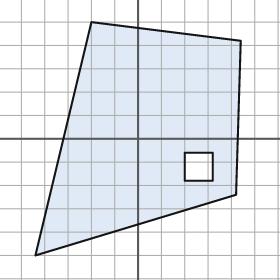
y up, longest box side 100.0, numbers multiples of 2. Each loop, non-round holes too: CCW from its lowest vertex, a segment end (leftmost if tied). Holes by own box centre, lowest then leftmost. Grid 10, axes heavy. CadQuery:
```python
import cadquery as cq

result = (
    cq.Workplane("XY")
    .moveTo(-44.0, -50.0)
    .lineTo(42.0, -24.0)
    .lineTo(44.0, 42.0)
    .lineTo(-20.0, 50.0)
    .close()
    .moveTo(20.0, -18.0)
    .lineTo(32.0, -18.0)
    .lineTo(32.0, -6.0)
    .lineTo(20.0, -6.0)
    .close()
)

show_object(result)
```